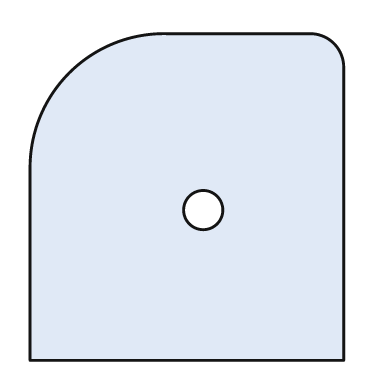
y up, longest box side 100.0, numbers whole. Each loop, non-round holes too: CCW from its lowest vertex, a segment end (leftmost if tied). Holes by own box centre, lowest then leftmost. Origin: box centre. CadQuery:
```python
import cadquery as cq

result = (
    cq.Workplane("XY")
    .moveTo(-48.0, -50.0)
    .lineTo(48.0, -50.0)
    .lineTo(48.0, 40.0)
    .threePointArc((45.0, 47.0), (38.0, 50.0))
    .lineTo(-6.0, 50.0)
    .threePointArc((-36.0, 38.0), (-48.0, 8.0))
    .close()
    .moveTo(5.0, -4.0)
    .circle(6.0)
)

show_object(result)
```